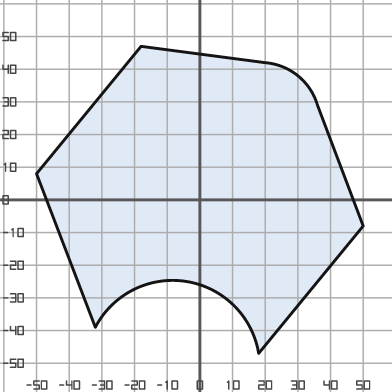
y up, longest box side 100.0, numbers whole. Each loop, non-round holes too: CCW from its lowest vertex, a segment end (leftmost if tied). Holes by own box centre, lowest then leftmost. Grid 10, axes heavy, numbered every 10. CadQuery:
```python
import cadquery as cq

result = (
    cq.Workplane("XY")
    .moveTo(18.0, -47.0)
    .lineTo(50.0, -8.0)
    .lineTo(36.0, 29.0)
    .threePointArc((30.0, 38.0), (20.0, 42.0))
    .lineTo(-18.0, 47.0)
    .lineTo(-50.0, 8.0)
    .lineTo(-32.0, -39.0)
    .threePointArc((-4.0, -25.0), (18.0, -47.0))
    .close()
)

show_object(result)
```